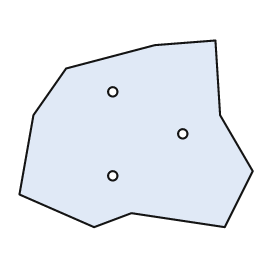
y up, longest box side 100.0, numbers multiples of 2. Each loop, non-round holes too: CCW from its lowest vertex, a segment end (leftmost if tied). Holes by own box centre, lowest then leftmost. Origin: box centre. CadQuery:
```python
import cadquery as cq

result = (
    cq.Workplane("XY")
    .moveTo(-18.0, -40.0)
    .lineTo(-2.0, -34.0)
    .lineTo(38.0, -40.0)
    .lineTo(50.0, -16.0)
    .lineTo(36.0, 8.0)
    .lineTo(34.0, 40.0)
    .lineTo(8.0, 38.0)
    .lineTo(-30.0, 28.0)
    .lineTo(-44.0, 8.0)
    .lineTo(-50.0, -26.0)
    .close()
    .moveTo(-10.0, -18.0)
    .circle(2.0)
    .moveTo(20.0, 0.0)
    .circle(2.0)
    .moveTo(-10.0, 18.0)
    .circle(2.0)
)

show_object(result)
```